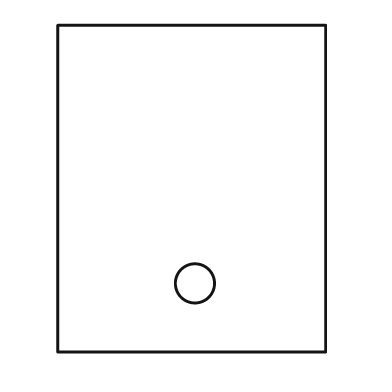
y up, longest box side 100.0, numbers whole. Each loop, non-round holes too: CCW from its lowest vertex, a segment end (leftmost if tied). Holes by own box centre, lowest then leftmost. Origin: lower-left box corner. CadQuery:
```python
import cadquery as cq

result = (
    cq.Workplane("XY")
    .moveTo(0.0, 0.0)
    .lineTo(82.0, 0.0)
    .lineTo(82.0, 100.0)
    .lineTo(0.0, 100.0)
    .close()
    .moveTo(42.0, 21.0)
    .circle(6.0)
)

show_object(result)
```